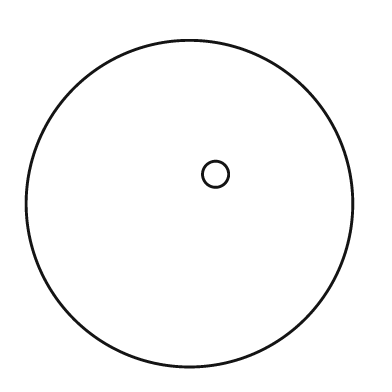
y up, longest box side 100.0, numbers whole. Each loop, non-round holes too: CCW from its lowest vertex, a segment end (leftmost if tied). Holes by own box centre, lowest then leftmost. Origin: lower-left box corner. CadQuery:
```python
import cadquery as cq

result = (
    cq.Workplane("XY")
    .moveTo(50.0, 50.0)
    .circle(50.0)
    .moveTo(58.0, 59.0)
    .circle(4.0)
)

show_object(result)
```